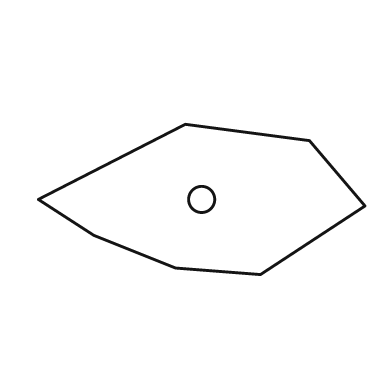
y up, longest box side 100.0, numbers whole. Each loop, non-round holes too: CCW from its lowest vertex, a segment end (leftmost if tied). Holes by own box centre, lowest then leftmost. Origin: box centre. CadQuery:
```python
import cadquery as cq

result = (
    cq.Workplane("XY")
    .moveTo(18.0, -23.0)
    .lineTo(50.0, -2.0)
    .lineTo(33.0, 18.0)
    .lineTo(-5.0, 23.0)
    .lineTo(-50.0, 0.0)
    .lineTo(-33.0, -11.0)
    .lineTo(-8.0, -21.0)
    .close()
    .moveTo(0.0, 0.0)
    .circle(4.0)
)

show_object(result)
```